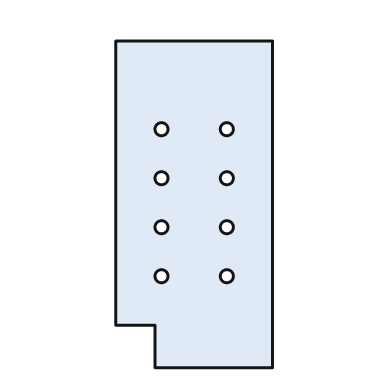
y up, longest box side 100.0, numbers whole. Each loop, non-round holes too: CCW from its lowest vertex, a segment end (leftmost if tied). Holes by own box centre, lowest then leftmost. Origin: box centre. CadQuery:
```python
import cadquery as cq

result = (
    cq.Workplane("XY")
    .moveTo(-12.0, -50.0)
    .lineTo(24.0, -50.0)
    .lineTo(24.0, 50.0)
    .lineTo(-24.0, 50.0)
    .lineTo(-24.0, -37.0)
    .lineTo(-12.0, -37.0)
    .close()
    .moveTo(-10.0, -22.0)
    .circle(2.0)
    .moveTo(10.0, -22.0)
    .circle(2.0)
    .moveTo(-10.0, -7.0)
    .circle(2.0)
    .moveTo(10.0, -7.0)
    .circle(2.0)
    .moveTo(-10.0, 8.0)
    .circle(2.0)
    .moveTo(10.0, 8.0)
    .circle(2.0)
    .moveTo(-10.0, 23.0)
    .circle(2.0)
    .moveTo(10.0, 23.0)
    .circle(2.0)
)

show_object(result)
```